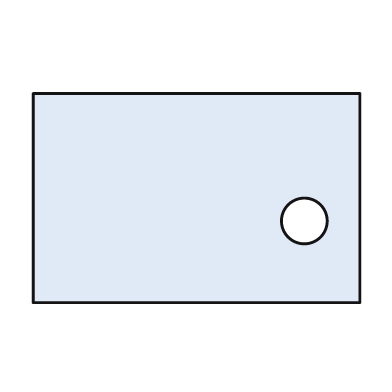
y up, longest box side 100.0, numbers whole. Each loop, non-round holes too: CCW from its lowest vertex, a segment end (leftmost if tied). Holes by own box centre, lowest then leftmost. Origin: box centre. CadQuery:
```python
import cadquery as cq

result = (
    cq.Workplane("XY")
    .moveTo(-50.0, -32.0)
    .lineTo(50.0, -32.0)
    .lineTo(50.0, 32.0)
    .lineTo(-50.0, 32.0)
    .close()
    .moveTo(33.0, -7.0)
    .circle(7.0)
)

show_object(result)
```